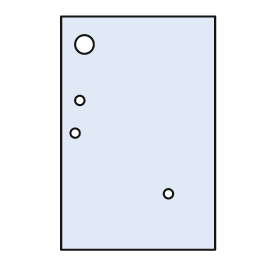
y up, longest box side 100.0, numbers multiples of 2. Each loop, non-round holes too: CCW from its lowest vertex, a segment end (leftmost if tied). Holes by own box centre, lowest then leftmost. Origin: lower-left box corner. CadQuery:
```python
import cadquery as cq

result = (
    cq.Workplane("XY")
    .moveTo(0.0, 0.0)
    .lineTo(66.0, 0.0)
    .lineTo(66.0, 100.0)
    .lineTo(0.0, 100.0)
    .close()
    .moveTo(46.0, 24.0)
    .circle(2.0)
    .moveTo(6.0, 50.0)
    .circle(2.0)
    .moveTo(8.0, 64.0)
    .circle(2.0)
    .moveTo(10.0, 88.0)
    .circle(4.0)
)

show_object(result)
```